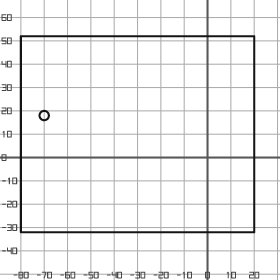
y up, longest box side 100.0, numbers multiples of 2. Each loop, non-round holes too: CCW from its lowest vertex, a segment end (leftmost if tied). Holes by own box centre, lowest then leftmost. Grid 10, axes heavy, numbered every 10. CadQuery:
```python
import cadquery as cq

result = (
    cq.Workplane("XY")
    .moveTo(-80.0, -32.0)
    .lineTo(20.0, -32.0)
    .lineTo(20.0, 52.0)
    .lineTo(-80.0, 52.0)
    .close()
    .moveTo(-70.0, 18.0)
    .circle(2.0)
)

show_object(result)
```